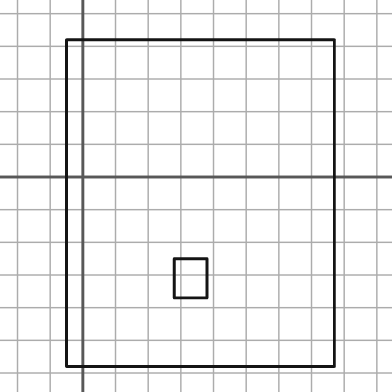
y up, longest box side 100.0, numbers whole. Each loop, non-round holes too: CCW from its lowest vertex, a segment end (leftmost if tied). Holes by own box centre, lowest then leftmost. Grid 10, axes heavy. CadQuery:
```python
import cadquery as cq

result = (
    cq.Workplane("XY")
    .moveTo(-5.0, -58.0)
    .lineTo(77.0, -58.0)
    .lineTo(77.0, 42.0)
    .lineTo(-5.0, 42.0)
    .close()
    .moveTo(28.0, -37.0)
    .lineTo(38.0, -37.0)
    .lineTo(38.0, -25.0)
    .lineTo(28.0, -25.0)
    .close()
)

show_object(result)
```